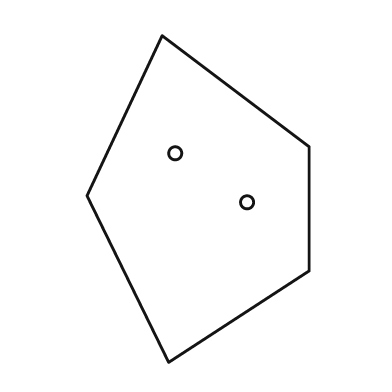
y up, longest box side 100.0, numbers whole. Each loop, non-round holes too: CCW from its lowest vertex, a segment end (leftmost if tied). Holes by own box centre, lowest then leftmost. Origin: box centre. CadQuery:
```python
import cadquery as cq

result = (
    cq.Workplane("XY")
    .moveTo(-9.0, -50.0)
    .lineTo(34.0, -22.0)
    .lineTo(34.0, 16.0)
    .lineTo(-11.0, 50.0)
    .lineTo(-34.0, 1.0)
    .close()
    .moveTo(15.0, -1.0)
    .circle(2.0)
    .moveTo(-7.0, 14.0)
    .circle(2.0)
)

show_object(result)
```